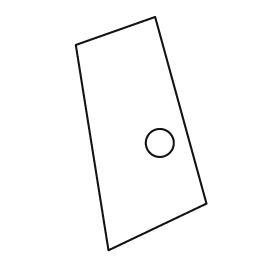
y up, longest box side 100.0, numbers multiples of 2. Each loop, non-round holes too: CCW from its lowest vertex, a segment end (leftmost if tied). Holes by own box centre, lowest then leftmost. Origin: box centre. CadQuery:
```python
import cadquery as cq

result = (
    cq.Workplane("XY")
    .moveTo(-14.0, -50.0)
    .lineTo(28.0, -30.0)
    .lineTo(6.0, 50.0)
    .lineTo(-28.0, 38.0)
    .close()
    .moveTo(8.0, -4.0)
    .circle(6.0)
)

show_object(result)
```